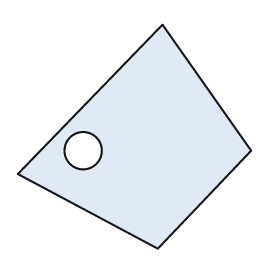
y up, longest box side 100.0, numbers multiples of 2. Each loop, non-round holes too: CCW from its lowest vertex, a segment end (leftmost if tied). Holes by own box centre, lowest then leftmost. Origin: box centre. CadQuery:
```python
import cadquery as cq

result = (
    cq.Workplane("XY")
    .moveTo(10.0, -48.0)
    .lineTo(50.0, -6.0)
    .lineTo(12.0, 48.0)
    .lineTo(-50.0, -16.0)
    .close()
    .moveTo(-22.0, -6.0)
    .circle(8.0)
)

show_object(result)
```